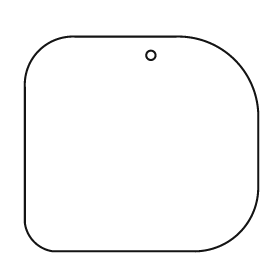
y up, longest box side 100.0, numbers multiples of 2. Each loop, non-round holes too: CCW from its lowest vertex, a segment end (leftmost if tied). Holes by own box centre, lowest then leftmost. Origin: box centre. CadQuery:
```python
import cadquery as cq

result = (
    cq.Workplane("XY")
    .moveTo(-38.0, -46.0)
    .lineTo(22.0, -46.0)
    .threePointArc((42.0, -38.0), (50.0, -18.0))
    .lineTo(50.0, 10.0)
    .threePointArc((40.0, 36.0), (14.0, 46.0))
    .lineTo(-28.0, 46.0)
    .threePointArc((-44.0, 40.0), (-50.0, 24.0))
    .lineTo(-50.0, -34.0)
    .threePointArc((-46.0, -42.0), (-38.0, -46.0))
    .close()
    .moveTo(4.0, 38.0)
    .circle(2.0)
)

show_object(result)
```